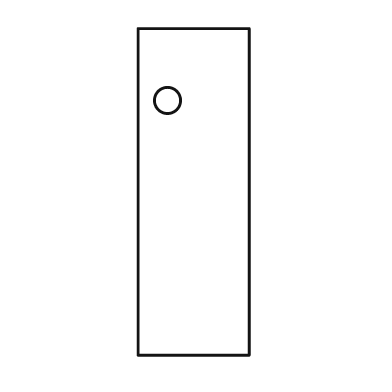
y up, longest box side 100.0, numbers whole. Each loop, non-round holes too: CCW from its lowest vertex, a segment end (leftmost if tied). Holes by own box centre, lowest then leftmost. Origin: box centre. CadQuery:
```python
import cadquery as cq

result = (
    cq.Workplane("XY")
    .moveTo(-17.0, -50.0)
    .lineTo(17.0, -50.0)
    .lineTo(17.0, 50.0)
    .lineTo(-17.0, 50.0)
    .close()
    .moveTo(-8.0, 28.0)
    .circle(4.0)
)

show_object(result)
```